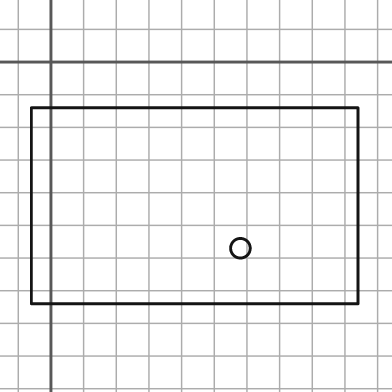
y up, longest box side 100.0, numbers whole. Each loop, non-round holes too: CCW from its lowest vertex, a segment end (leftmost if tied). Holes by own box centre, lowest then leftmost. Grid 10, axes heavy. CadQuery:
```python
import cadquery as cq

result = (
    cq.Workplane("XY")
    .moveTo(-6.0, -74.0)
    .lineTo(94.0, -74.0)
    .lineTo(94.0, -14.0)
    .lineTo(-6.0, -14.0)
    .close()
    .moveTo(58.0, -57.0)
    .circle(3.0)
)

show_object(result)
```